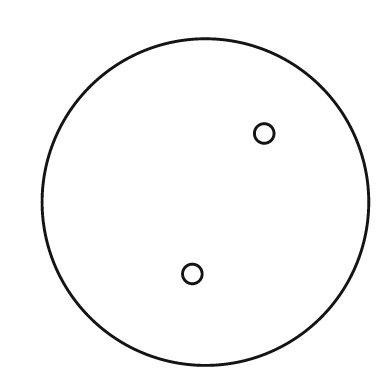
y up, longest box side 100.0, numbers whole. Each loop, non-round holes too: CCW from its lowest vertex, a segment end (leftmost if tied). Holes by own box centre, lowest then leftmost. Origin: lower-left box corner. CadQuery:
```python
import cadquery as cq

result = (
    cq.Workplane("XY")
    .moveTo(50.0, 50.0)
    .circle(50.0)
    .moveTo(46.0, 28.0)
    .circle(3.0)
    .moveTo(68.0, 71.0)
    .circle(3.0)
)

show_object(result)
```